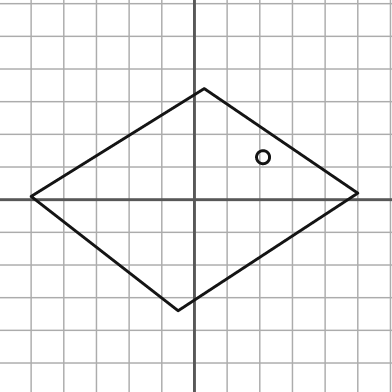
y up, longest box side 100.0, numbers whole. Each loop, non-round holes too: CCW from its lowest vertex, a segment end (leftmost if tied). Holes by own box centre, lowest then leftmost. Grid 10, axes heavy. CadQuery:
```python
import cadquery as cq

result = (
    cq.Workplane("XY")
    .moveTo(-5.0, -34.0)
    .lineTo(50.0, 2.0)
    .lineTo(3.0, 34.0)
    .lineTo(-50.0, 1.0)
    .close()
    .moveTo(21.0, 13.0)
    .circle(2.0)
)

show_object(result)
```